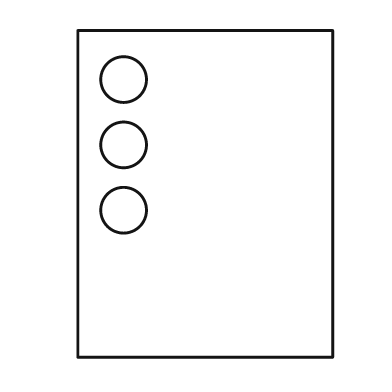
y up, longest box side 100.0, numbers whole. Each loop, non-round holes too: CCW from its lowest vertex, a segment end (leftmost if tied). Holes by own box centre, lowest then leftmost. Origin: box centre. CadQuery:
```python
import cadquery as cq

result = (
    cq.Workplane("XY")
    .moveTo(-39.0, -50.0)
    .lineTo(39.0, -50.0)
    .lineTo(39.0, 50.0)
    .lineTo(-39.0, 50.0)
    .close()
    .moveTo(-25.0, -5.0)
    .circle(7.0)
    .moveTo(-25.0, 15.0)
    .circle(7.0)
    .moveTo(-25.0, 35.0)
    .circle(7.0)
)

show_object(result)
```